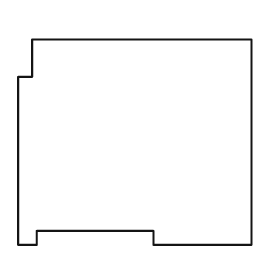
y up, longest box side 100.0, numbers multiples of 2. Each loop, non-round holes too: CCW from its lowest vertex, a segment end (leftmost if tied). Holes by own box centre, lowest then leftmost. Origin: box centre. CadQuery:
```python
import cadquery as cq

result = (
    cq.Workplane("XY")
    .moveTo(-50.0, -44.0)
    .lineTo(-42.0, -44.0)
    .lineTo(-42.0, -38.0)
    .lineTo(8.0, -38.0)
    .lineTo(8.0, -44.0)
    .lineTo(50.0, -44.0)
    .lineTo(50.0, 44.0)
    .lineTo(-44.0, 44.0)
    .lineTo(-44.0, 28.0)
    .lineTo(-50.0, 28.0)
    .close()
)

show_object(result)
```